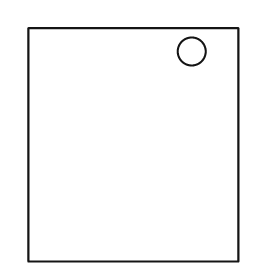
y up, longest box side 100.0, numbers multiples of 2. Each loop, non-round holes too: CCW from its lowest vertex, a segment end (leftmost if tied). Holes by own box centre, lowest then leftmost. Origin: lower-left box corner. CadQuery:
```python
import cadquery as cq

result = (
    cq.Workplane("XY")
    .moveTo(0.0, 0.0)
    .lineTo(90.0, 0.0)
    .lineTo(90.0, 100.0)
    .lineTo(0.0, 100.0)
    .close()
    .moveTo(70.0, 90.0)
    .circle(6.0)
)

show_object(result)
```